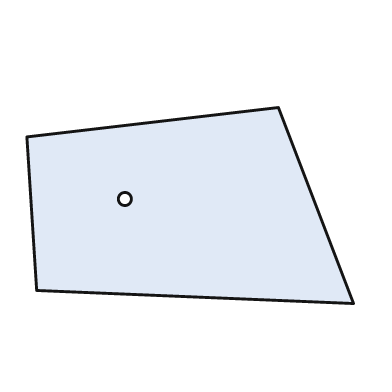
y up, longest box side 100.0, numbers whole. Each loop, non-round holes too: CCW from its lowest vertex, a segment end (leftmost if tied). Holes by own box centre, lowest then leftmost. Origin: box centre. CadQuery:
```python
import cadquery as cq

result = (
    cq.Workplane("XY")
    .moveTo(50.0, -30.0)
    .lineTo(27.0, 30.0)
    .lineTo(-50.0, 21.0)
    .lineTo(-47.0, -26.0)
    .close()
    .moveTo(-20.0, 2.0)
    .circle(2.0)
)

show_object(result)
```